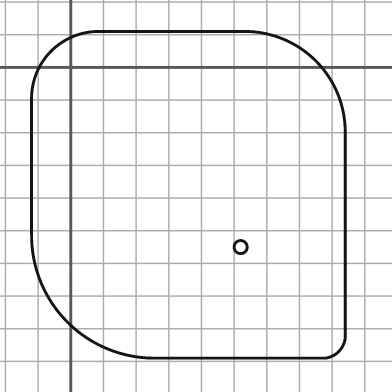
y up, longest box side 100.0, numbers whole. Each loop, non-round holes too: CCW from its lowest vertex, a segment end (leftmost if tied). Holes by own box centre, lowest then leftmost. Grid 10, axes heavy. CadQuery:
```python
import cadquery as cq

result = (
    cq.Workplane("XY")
    .moveTo(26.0, -89.0)
    .lineTo(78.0, -89.0)
    .threePointArc((82.0, -87.0), (84.0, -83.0))
    .lineTo(84.0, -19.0)
    .threePointArc((75.0, 2.0), (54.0, 11.0))
    .lineTo(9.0, 11.0)
    .threePointArc((-6.0, 5.0), (-12.0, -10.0))
    .lineTo(-12.0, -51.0)
    .threePointArc((-1.0, -78.0), (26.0, -89.0))
    .close()
    .moveTo(52.0, -55.0)
    .circle(2.0)
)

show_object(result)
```